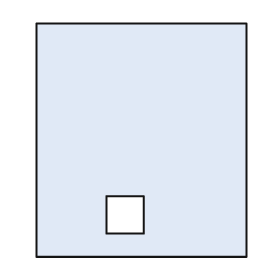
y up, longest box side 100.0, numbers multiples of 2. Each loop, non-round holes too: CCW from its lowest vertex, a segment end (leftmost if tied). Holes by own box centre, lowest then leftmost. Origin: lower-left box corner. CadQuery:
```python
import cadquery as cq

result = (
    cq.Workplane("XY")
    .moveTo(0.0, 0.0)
    .lineTo(90.0, 0.0)
    .lineTo(90.0, 100.0)
    .lineTo(0.0, 100.0)
    .close()
    .moveTo(30.0, 10.0)
    .lineTo(46.0, 10.0)
    .lineTo(46.0, 26.0)
    .lineTo(30.0, 26.0)
    .close()
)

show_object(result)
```